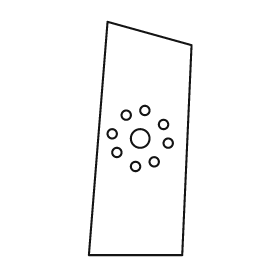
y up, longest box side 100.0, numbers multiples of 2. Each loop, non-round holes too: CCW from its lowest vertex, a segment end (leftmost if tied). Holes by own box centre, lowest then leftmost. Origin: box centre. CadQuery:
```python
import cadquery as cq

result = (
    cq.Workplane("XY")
    .moveTo(-22.0, -50.0)
    .lineTo(18.0, -50.0)
    .lineTo(22.0, 40.0)
    .lineTo(-14.0, 50.0)
    .close()
    .moveTo(-2.0, -12.0)
    .circle(2.0)
    .moveTo(6.0, -10.0)
    .circle(2.0)
    .moveTo(-10.0, -6.0)
    .circle(2.0)
    .moveTo(12.0, -2.0)
    .circle(2.0)
    .moveTo(0.0, 0.0)
    .circle(4.0)
    .moveTo(-12.0, 2.0)
    .circle(2.0)
    .moveTo(10.0, 6.0)
    .circle(2.0)
    .moveTo(-6.0, 10.0)
    .circle(2.0)
    .moveTo(2.0, 12.0)
    .circle(2.0)
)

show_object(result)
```